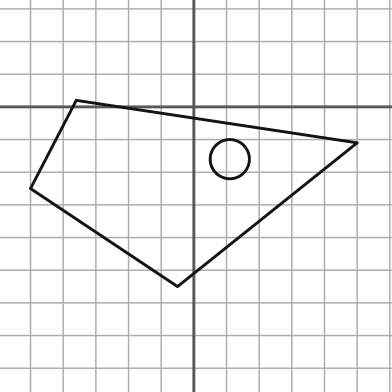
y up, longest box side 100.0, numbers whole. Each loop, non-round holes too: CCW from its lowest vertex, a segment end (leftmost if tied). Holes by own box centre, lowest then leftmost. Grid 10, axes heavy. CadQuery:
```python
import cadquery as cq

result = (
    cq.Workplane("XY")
    .moveTo(-5.0, -55.0)
    .lineTo(50.0, -11.0)
    .lineTo(-36.0, 2.0)
    .lineTo(-50.0, -25.0)
    .close()
    .moveTo(11.0, -16.0)
    .circle(6.0)
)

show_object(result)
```